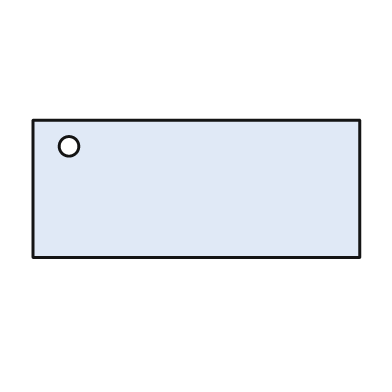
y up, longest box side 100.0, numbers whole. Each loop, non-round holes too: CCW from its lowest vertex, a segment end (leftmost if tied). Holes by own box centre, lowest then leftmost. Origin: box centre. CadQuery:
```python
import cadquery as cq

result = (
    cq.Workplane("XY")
    .moveTo(-50.0, -21.0)
    .lineTo(50.0, -21.0)
    .lineTo(50.0, 21.0)
    .lineTo(-50.0, 21.0)
    .close()
    .moveTo(-39.0, 13.0)
    .circle(3.0)
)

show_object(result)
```